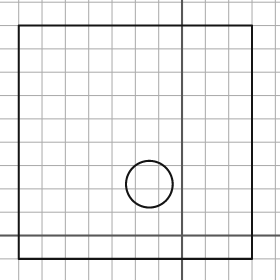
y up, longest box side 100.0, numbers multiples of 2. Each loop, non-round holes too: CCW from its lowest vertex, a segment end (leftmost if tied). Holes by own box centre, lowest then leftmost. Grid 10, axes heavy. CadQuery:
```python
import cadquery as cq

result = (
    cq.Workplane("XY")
    .moveTo(-70.0, -10.0)
    .lineTo(30.0, -10.0)
    .lineTo(30.0, 90.0)
    .lineTo(-70.0, 90.0)
    .close()
    .moveTo(-14.0, 22.0)
    .circle(10.0)
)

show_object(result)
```